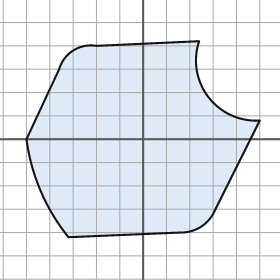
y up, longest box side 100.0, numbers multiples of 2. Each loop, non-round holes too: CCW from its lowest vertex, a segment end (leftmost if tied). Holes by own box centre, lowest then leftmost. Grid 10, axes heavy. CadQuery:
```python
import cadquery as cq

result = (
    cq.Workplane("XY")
    .moveTo(-32.0, -42.0)
    .lineTo(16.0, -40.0)
    .threePointArc((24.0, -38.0), (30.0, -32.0))
    .lineTo(50.0, 8.0)
    .threePointArc((28.0, 18.0), (24.0, 42.0))
    .lineTo(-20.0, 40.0)
    .threePointArc((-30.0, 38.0), (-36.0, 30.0))
    .lineTo(-50.0, 0.0)
    .threePointArc((-44.0, -22.0), (-32.0, -42.0))
    .close()
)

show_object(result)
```